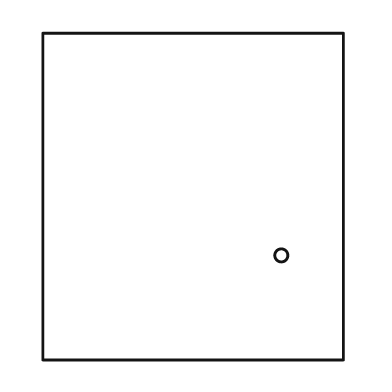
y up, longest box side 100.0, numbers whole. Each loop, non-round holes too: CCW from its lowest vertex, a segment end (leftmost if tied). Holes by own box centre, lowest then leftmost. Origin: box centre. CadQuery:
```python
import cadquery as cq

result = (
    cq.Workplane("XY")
    .moveTo(-46.0, -50.0)
    .lineTo(46.0, -50.0)
    .lineTo(46.0, 50.0)
    .lineTo(-46.0, 50.0)
    .close()
    .moveTo(27.0, -18.0)
    .circle(2.0)
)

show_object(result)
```